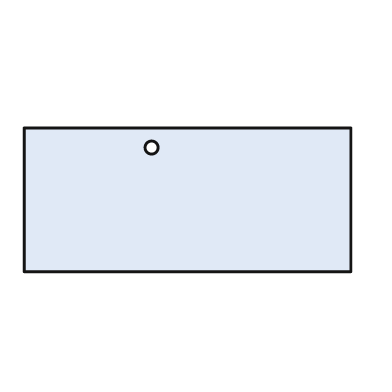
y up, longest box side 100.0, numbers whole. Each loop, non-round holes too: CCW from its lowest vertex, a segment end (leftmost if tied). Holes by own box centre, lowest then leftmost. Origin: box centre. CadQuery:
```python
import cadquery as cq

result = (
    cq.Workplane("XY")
    .moveTo(-50.0, -22.0)
    .lineTo(50.0, -22.0)
    .lineTo(50.0, 22.0)
    .lineTo(-50.0, 22.0)
    .close()
    .moveTo(-11.0, 16.0)
    .circle(2.0)
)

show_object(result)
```